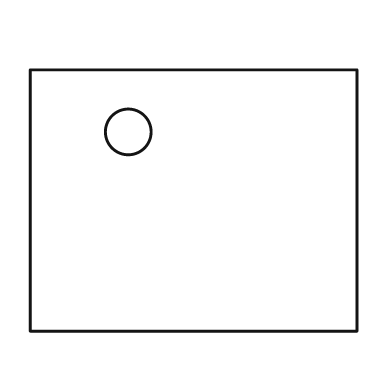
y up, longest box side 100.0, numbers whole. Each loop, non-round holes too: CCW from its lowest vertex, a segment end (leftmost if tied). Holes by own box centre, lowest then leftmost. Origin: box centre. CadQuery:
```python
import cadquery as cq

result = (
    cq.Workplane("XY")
    .moveTo(-50.0, -40.0)
    .lineTo(50.0, -40.0)
    .lineTo(50.0, 40.0)
    .lineTo(-50.0, 40.0)
    .close()
    .moveTo(-20.0, 21.0)
    .circle(7.0)
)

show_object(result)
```